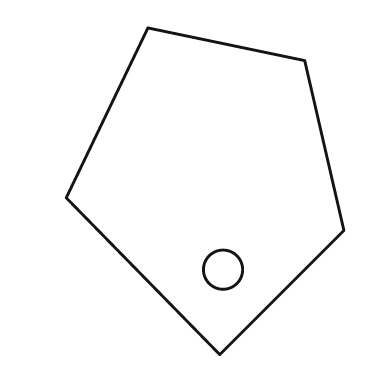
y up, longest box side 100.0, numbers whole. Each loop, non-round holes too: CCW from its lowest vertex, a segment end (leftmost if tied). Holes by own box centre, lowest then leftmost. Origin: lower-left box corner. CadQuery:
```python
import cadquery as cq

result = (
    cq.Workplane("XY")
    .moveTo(47.0, 0.0)
    .lineTo(85.0, 38.0)
    .lineTo(73.0, 90.0)
    .lineTo(25.0, 100.0)
    .lineTo(0.0, 48.0)
    .close()
    .moveTo(48.0, 26.0)
    .circle(6.0)
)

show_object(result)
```